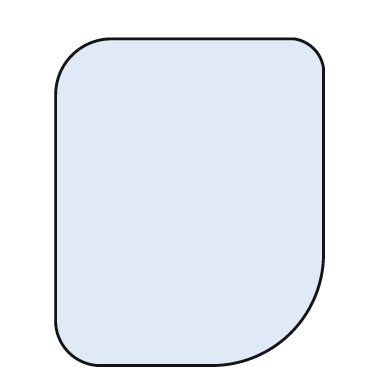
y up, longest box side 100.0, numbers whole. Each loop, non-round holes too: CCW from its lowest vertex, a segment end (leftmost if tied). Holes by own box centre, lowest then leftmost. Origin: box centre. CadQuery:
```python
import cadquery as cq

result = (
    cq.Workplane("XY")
    .moveTo(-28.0, -50.0)
    .lineTo(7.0, -50.0)
    .threePointArc((31.0, -40.0), (41.0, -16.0))
    .lineTo(41.0, 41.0)
    .threePointArc((38.0, 47.0), (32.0, 50.0))
    .lineTo(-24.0, 50.0)
    .threePointArc((-36.0, 45.0), (-41.0, 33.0))
    .lineTo(-41.0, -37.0)
    .threePointArc((-37.0, -46.0), (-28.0, -50.0))
    .close()
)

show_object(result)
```